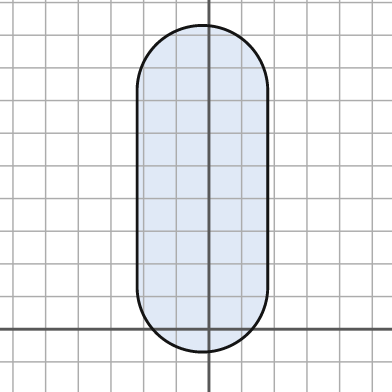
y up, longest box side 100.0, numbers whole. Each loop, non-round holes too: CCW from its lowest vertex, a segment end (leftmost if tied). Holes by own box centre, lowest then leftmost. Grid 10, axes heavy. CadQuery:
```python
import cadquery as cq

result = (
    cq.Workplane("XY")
    .moveTo(-22.0, 13.0)
    .threePointArc((-2.0, -7.0), (18.0, 13.0))
    .lineTo(18.0, 73.0)
    .threePointArc((-2.0, 93.0), (-22.0, 73.0))
    .close()
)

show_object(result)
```